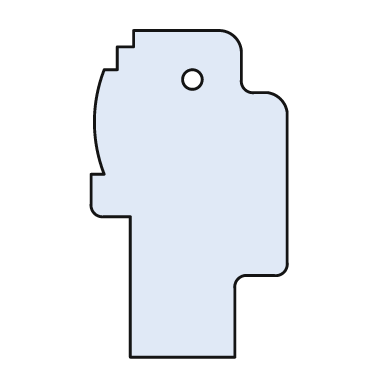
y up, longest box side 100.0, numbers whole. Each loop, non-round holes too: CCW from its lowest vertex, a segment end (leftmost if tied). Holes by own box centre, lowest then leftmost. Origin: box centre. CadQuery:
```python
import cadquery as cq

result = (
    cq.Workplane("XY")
    .moveTo(-18.0, -50.0)
    .lineTo(14.0, -50.0)
    .lineTo(14.0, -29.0)
    .threePointArc((15.0, -26.0), (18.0, -25.0))
    .lineTo(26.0, -25.0)
    .threePointArc((29.0, -24.0), (30.0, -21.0))
    .lineTo(30.0, 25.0)
    .threePointArc((28.0, 29.0), (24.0, 31.0))
    .lineTo(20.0, 31.0)
    .threePointArc((17.0, 32.0), (16.0, 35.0))
    .lineTo(16.0, 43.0)
    .threePointArc((14.0, 48.0), (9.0, 50.0))
    .lineTo(-17.0, 50.0)
    .lineTo(-17.0, 45.0)
    .lineTo(-22.0, 45.0)
    .lineTo(-22.0, 38.0)
    .lineTo(-26.0, 38.0)
    .threePointArc((-29.0, 22.0), (-26.0, 6.0))
    .lineTo(-30.0, 6.0)
    .lineTo(-30.0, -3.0)
    .threePointArc((-29.0, -6.0), (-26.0, -7.0))
    .lineTo(-18.0, -7.0)
    .close()
    .moveTo(1.0, 35.0)
    .circle(3.0)
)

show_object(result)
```